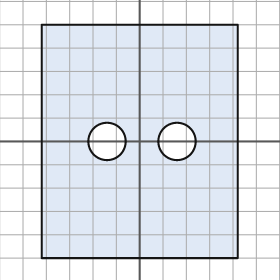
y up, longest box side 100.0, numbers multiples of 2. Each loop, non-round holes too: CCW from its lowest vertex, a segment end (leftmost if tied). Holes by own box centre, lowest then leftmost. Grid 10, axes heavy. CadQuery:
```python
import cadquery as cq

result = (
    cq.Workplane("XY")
    .moveTo(-42.0, -50.0)
    .lineTo(42.0, -50.0)
    .lineTo(42.0, 50.0)
    .lineTo(-42.0, 50.0)
    .close()
    .moveTo(-14.0, 0.0)
    .circle(8.0)
    .moveTo(16.0, 0.0)
    .circle(8.0)
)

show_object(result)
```